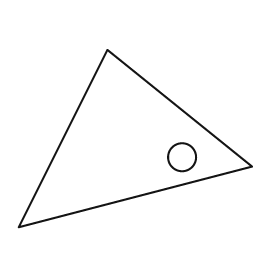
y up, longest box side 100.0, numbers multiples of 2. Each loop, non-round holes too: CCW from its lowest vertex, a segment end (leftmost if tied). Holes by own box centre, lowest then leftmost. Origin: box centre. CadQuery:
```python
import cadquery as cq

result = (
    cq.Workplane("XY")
    .moveTo(-50.0, -38.0)
    .lineTo(50.0, -12.0)
    .lineTo(-12.0, 38.0)
    .close()
    .moveTo(20.0, -8.0)
    .circle(6.0)
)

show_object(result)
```